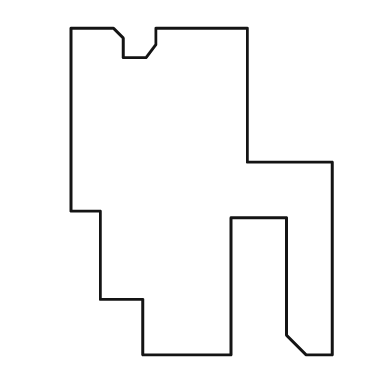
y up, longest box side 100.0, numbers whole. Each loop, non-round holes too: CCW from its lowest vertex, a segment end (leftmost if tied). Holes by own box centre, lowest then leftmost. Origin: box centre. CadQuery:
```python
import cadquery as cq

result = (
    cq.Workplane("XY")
    .moveTo(-18.0, -50.0)
    .lineTo(9.0, -50.0)
    .lineTo(9.0, -8.0)
    .lineTo(26.0, -8.0)
    .lineTo(26.0, -44.0)
    .lineTo(32.0, -50.0)
    .lineTo(40.0, -50.0)
    .lineTo(40.0, 9.0)
    .lineTo(14.0, 9.0)
    .lineTo(14.0, 50.0)
    .lineTo(-14.0, 50.0)
    .lineTo(-14.0, 45.0)
    .lineTo(-17.0, 41.0)
    .lineTo(-24.0, 41.0)
    .lineTo(-24.0, 47.0)
    .lineTo(-27.0, 50.0)
    .lineTo(-40.0, 50.0)
    .lineTo(-40.0, -6.0)
    .lineTo(-31.0, -6.0)
    .lineTo(-31.0, -33.0)
    .lineTo(-18.0, -33.0)
    .close()
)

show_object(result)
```